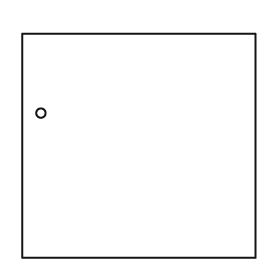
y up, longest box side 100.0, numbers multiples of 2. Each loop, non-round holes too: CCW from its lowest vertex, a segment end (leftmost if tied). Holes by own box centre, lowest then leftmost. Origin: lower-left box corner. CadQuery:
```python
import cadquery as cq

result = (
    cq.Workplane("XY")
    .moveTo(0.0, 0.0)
    .lineTo(100.0, 0.0)
    .lineTo(100.0, 96.0)
    .lineTo(0.0, 96.0)
    .close()
    .moveTo(8.0, 62.0)
    .circle(2.0)
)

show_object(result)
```